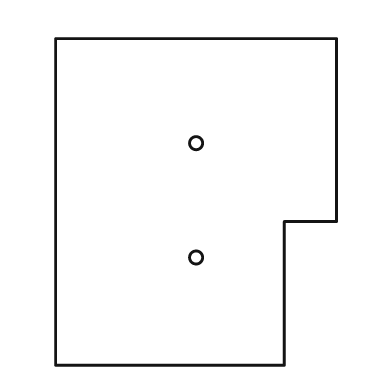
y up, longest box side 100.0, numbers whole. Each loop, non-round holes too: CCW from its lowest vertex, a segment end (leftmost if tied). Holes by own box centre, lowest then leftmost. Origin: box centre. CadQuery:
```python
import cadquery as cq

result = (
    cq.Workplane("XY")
    .moveTo(-43.0, -50.0)
    .lineTo(27.0, -50.0)
    .lineTo(27.0, -6.0)
    .lineTo(43.0, -6.0)
    .lineTo(43.0, 50.0)
    .lineTo(-43.0, 50.0)
    .close()
    .moveTo(0.0, -17.0)
    .circle(2.0)
    .moveTo(0.0, 18.0)
    .circle(2.0)
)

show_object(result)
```